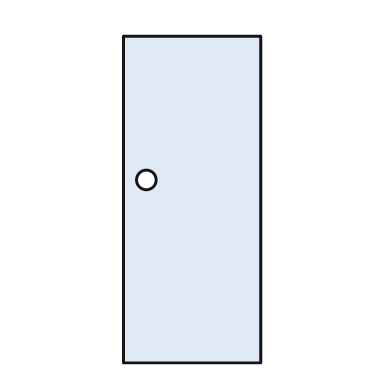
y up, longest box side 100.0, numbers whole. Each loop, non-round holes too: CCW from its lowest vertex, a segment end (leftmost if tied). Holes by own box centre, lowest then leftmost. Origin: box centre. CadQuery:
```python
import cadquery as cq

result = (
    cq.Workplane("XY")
    .moveTo(-21.0, -50.0)
    .lineTo(21.0, -50.0)
    .lineTo(21.0, 50.0)
    .lineTo(-21.0, 50.0)
    .close()
    .moveTo(-14.0, 6.0)
    .circle(3.0)
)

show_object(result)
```